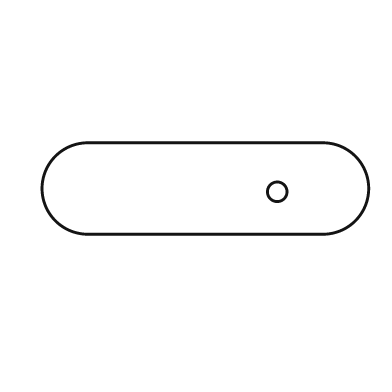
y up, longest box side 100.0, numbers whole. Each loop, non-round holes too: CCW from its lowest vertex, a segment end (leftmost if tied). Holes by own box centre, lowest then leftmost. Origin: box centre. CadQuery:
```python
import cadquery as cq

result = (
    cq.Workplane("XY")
    .moveTo(-36.0, -14.0)
    .lineTo(36.0, -14.0)
    .threePointArc((50.0, 0.0), (36.0, 14.0))
    .lineTo(-36.0, 14.0)
    .threePointArc((-50.0, 0.0), (-36.0, -14.0))
    .close()
    .moveTo(22.0, -1.0)
    .circle(3.0)
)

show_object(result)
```